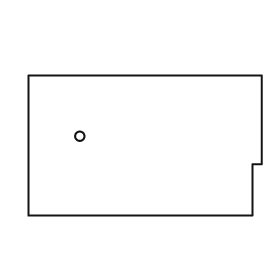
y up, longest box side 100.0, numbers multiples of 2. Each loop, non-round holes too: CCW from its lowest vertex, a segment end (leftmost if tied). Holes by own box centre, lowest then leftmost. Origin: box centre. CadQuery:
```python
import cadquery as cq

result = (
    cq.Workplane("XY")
    .moveTo(-50.0, -30.0)
    .lineTo(46.0, -30.0)
    .lineTo(46.0, -8.0)
    .lineTo(50.0, -8.0)
    .lineTo(50.0, 30.0)
    .lineTo(-50.0, 30.0)
    .close()
    .moveTo(-28.0, 4.0)
    .circle(2.0)
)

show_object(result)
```